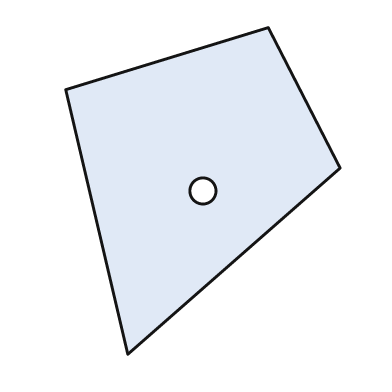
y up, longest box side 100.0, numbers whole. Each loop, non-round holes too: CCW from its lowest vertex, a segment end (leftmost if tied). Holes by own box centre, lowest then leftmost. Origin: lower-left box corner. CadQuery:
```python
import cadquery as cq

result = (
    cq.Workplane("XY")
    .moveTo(19.0, 0.0)
    .lineTo(84.0, 57.0)
    .lineTo(62.0, 100.0)
    .lineTo(0.0, 81.0)
    .close()
    .moveTo(42.0, 50.0)
    .circle(4.0)
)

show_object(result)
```